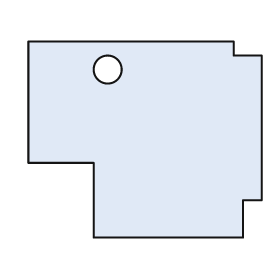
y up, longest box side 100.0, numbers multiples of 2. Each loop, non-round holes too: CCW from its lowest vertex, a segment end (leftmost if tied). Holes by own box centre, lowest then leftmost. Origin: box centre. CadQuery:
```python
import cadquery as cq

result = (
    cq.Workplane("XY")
    .moveTo(-22.0, -42.0)
    .lineTo(42.0, -42.0)
    .lineTo(42.0, -26.0)
    .lineTo(50.0, -26.0)
    .lineTo(50.0, 36.0)
    .lineTo(38.0, 36.0)
    .lineTo(38.0, 42.0)
    .lineTo(-50.0, 42.0)
    .lineTo(-50.0, -10.0)
    .lineTo(-22.0, -10.0)
    .close()
    .moveTo(-16.0, 30.0)
    .circle(6.0)
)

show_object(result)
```